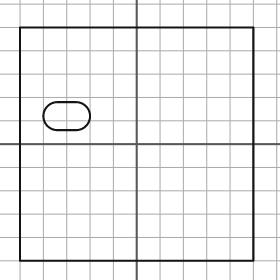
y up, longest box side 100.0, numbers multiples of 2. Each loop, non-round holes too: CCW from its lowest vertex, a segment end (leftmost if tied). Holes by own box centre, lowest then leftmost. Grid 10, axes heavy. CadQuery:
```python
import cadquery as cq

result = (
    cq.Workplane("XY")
    .moveTo(-50.0, -50.0)
    .lineTo(50.0, -50.0)
    .lineTo(50.0, 50.0)
    .lineTo(-50.0, 50.0)
    .close()
    .moveTo(-34.0, 6.0)
    .lineTo(-26.0, 6.0)
    .threePointArc((-20.0, 12.0), (-26.0, 18.0))
    .lineTo(-34.0, 18.0)
    .threePointArc((-40.0, 12.0), (-34.0, 6.0))
    .close()
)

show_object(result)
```